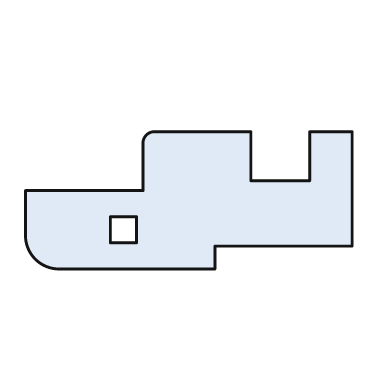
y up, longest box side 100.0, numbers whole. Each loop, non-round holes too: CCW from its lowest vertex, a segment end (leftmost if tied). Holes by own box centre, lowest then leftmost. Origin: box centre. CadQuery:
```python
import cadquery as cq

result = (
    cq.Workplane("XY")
    .moveTo(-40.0, -21.0)
    .lineTo(8.0, -21.0)
    .lineTo(8.0, -14.0)
    .lineTo(50.0, -14.0)
    .lineTo(50.0, 21.0)
    .lineTo(37.0, 21.0)
    .lineTo(37.0, 6.0)
    .lineTo(19.0, 6.0)
    .lineTo(19.0, 21.0)
    .lineTo(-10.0, 21.0)
    .threePointArc((-13.0, 20.0), (-14.0, 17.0))
    .lineTo(-14.0, 3.0)
    .lineTo(-50.0, 3.0)
    .lineTo(-50.0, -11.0)
    .threePointArc((-47.0, -18.0), (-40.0, -21.0))
    .close()
    .moveTo(-24.0, -13.0)
    .lineTo(-16.0, -13.0)
    .lineTo(-16.0, -5.0)
    .lineTo(-24.0, -5.0)
    .close()
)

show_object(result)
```